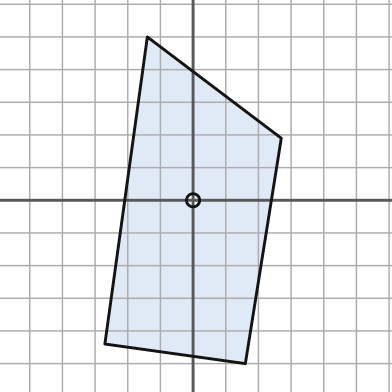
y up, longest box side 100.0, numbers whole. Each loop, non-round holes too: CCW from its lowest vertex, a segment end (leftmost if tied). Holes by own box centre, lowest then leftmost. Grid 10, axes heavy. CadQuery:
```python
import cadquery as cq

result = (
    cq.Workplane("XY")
    .moveTo(16.0, -50.0)
    .lineTo(27.0, 19.0)
    .lineTo(-14.0, 50.0)
    .lineTo(-27.0, -44.0)
    .close()
    .moveTo(0.0, 0.0)
    .circle(2.0)
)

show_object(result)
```